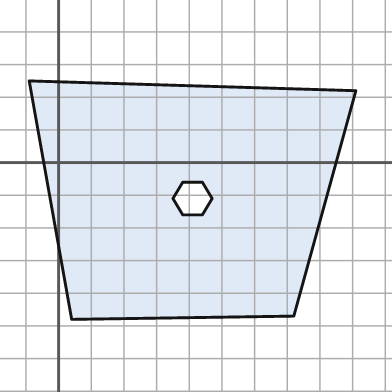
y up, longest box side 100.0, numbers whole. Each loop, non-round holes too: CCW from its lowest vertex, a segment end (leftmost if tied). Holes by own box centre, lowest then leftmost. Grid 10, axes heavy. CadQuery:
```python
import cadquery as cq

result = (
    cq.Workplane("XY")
    .moveTo(4.0, -48.0)
    .lineTo(72.0, -47.0)
    .lineTo(91.0, 22.0)
    .lineTo(-9.0, 25.0)
    .close()
    .moveTo(38.0, -16.0)
    .lineTo(44.0, -16.0)
    .lineTo(47.0, -11.0)
    .lineTo(44.0, -6.0)
    .lineTo(38.0, -6.0)
    .lineTo(35.0, -11.0)
    .close()
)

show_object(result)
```